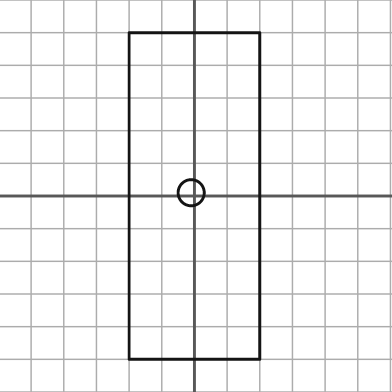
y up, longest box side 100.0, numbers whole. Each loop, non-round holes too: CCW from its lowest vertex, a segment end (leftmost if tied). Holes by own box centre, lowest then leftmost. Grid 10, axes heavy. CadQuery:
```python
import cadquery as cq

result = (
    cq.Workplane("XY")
    .moveTo(-20.0, -50.0)
    .lineTo(20.0, -50.0)
    .lineTo(20.0, 50.0)
    .lineTo(-20.0, 50.0)
    .close()
    .moveTo(-1.0, 1.0)
    .circle(4.0)
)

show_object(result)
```